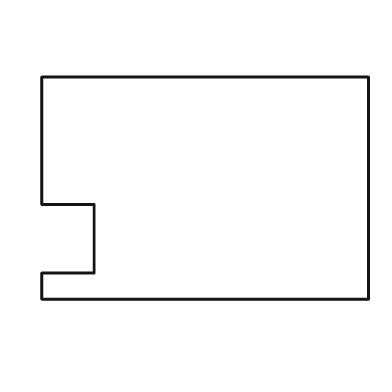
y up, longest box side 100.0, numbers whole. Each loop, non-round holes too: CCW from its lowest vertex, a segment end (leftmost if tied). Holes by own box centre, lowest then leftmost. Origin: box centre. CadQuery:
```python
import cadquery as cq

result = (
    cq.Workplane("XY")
    .moveTo(-50.0, -34.0)
    .lineTo(50.0, -34.0)
    .lineTo(50.0, 34.0)
    .lineTo(-50.0, 34.0)
    .lineTo(-50.0, -5.0)
    .lineTo(-34.0, -5.0)
    .lineTo(-34.0, -26.0)
    .lineTo(-50.0, -26.0)
    .close()
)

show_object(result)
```